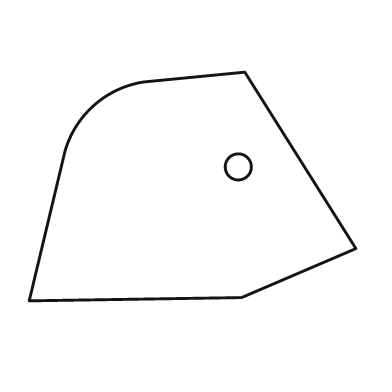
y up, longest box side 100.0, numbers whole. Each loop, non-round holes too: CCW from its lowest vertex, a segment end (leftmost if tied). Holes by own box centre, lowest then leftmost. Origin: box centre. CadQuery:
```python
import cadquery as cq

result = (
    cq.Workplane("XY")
    .moveTo(-50.0, -35.0)
    .lineTo(15.0, -34.0)
    .lineTo(50.0, -19.0)
    .lineTo(16.0, 35.0)
    .lineTo(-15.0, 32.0)
    .threePointArc((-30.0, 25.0), (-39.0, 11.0))
    .close()
    .moveTo(14.0, 6.0)
    .circle(4.0)
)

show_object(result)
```